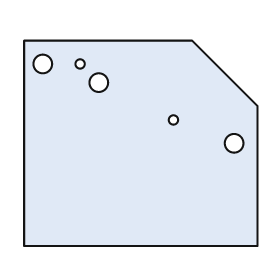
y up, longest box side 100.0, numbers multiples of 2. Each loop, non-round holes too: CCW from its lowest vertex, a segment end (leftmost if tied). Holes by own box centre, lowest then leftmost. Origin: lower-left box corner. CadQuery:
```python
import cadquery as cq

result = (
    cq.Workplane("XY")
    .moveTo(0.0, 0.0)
    .lineTo(100.0, 0.0)
    .lineTo(100.0, 60.0)
    .lineTo(72.0, 88.0)
    .lineTo(0.0, 88.0)
    .close()
    .moveTo(90.0, 44.0)
    .circle(4.0)
    .moveTo(64.0, 54.0)
    .circle(2.0)
    .moveTo(32.0, 70.0)
    .circle(4.0)
    .moveTo(8.0, 78.0)
    .circle(4.0)
    .moveTo(24.0, 78.0)
    .circle(2.0)
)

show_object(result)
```